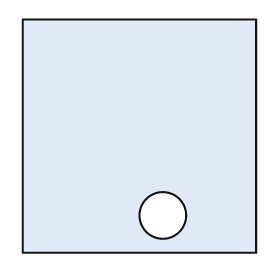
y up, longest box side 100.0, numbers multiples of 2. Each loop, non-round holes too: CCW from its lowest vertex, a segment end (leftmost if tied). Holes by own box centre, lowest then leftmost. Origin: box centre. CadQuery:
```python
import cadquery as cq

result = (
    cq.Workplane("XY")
    .moveTo(-50.0, -50.0)
    .lineTo(50.0, -50.0)
    .lineTo(50.0, 50.0)
    .lineTo(-50.0, 50.0)
    .close()
    .moveTo(10.0, -34.0)
    .circle(10.0)
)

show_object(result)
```